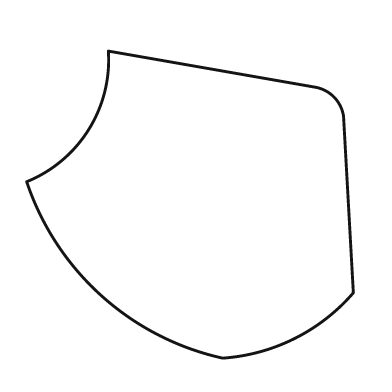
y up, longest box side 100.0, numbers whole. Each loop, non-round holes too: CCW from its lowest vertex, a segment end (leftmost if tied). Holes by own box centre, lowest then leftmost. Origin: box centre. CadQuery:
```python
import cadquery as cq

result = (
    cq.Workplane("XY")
    .moveTo(10.0, -47.0)
    .threePointArc((32.0, -41.0), (50.0, -27.0))
    .lineTo(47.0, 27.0)
    .threePointArc((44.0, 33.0), (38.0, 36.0))
    .lineTo(-25.0, 47.0)
    .threePointArc((-31.0, 23.0), (-50.0, 7.0))
    .threePointArc((-27.0, -28.0), (10.0, -47.0))
    .close()
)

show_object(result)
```